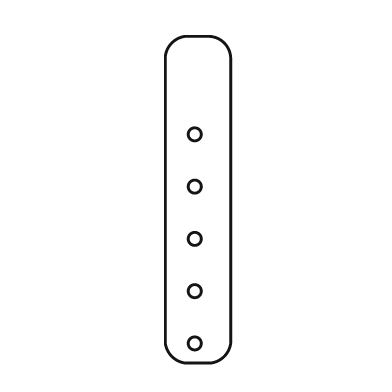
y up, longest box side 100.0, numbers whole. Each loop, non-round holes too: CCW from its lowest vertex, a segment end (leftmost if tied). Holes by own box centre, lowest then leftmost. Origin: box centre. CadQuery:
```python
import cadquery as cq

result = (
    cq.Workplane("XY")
    .moveTo(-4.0, -50.0)
    .lineTo(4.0, -50.0)
    .threePointArc((8.0, -48.0), (10.0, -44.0))
    .lineTo(10.0, 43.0)
    .threePointArc((8.0, 48.0), (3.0, 50.0))
    .lineTo(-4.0, 50.0)
    .threePointArc((-8.0, 48.0), (-10.0, 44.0))
    .lineTo(-10.0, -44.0)
    .threePointArc((-8.0, -48.0), (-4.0, -50.0))
    .close()
    .moveTo(-1.0, -44.0)
    .circle(2.0)
    .moveTo(-1.0, -28.0)
    .circle(2.0)
    .moveTo(-1.0, -12.0)
    .circle(2.0)
    .moveTo(-1.0, 4.0)
    .circle(2.0)
    .moveTo(-1.0, 20.0)
    .circle(2.0)
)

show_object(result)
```